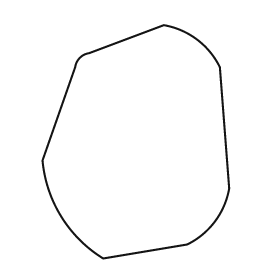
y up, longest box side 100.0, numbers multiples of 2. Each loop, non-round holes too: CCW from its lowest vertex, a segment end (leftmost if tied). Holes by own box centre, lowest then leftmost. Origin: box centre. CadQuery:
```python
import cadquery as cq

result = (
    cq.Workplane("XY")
    .moveTo(-14.0, -50.0)
    .lineTo(22.0, -44.0)
    .threePointArc((34.0, -34.0), (40.0, -20.0))
    .lineTo(36.0, 32.0)
    .threePointArc((26.0, 44.0), (12.0, 50.0))
    .lineTo(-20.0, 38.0)
    .threePointArc((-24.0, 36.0), (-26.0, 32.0))
    .lineTo(-40.0, -8.0)
    .threePointArc((-32.0, -32.0), (-14.0, -50.0))
    .close()
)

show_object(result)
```